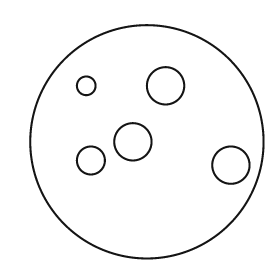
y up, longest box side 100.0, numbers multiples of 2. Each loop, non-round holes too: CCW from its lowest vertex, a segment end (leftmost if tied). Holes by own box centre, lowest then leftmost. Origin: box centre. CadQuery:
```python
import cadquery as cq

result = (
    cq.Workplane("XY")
    .moveTo(0.0, 0.0)
    .circle(50.0)
    .moveTo(36.0, -10.0)
    .circle(8.0)
    .moveTo(-24.0, -8.0)
    .circle(6.0)
    .moveTo(-6.0, 0.0)
    .circle(8.0)
    .moveTo(-26.0, 24.0)
    .circle(4.0)
    .moveTo(8.0, 24.0)
    .circle(8.0)
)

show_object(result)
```